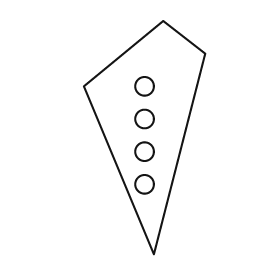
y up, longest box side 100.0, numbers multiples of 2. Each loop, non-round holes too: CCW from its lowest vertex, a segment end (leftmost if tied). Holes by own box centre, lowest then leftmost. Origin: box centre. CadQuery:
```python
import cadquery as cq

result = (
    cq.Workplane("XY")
    .moveTo(4.0, -50.0)
    .lineTo(26.0, 36.0)
    .lineTo(8.0, 50.0)
    .lineTo(-26.0, 22.0)
    .close()
    .moveTo(0.0, -20.0)
    .circle(4.0)
    .moveTo(0.0, -6.0)
    .circle(4.0)
    .moveTo(0.0, 8.0)
    .circle(4.0)
    .moveTo(0.0, 22.0)
    .circle(4.0)
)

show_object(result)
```